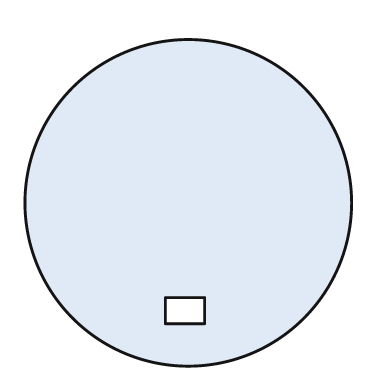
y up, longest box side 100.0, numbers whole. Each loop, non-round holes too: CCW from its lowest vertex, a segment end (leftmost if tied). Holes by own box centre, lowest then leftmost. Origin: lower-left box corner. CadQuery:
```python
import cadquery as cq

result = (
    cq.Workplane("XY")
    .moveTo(50.0, 50.0)
    .circle(50.0)
    .moveTo(43.0, 13.0)
    .lineTo(55.0, 13.0)
    .lineTo(55.0, 21.0)
    .lineTo(43.0, 21.0)
    .close()
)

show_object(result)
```